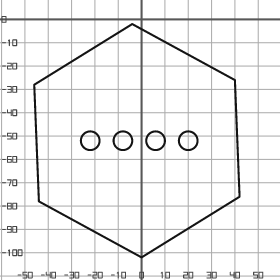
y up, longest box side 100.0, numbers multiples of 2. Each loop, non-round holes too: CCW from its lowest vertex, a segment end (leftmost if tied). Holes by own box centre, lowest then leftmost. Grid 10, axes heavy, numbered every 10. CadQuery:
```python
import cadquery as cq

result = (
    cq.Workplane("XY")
    .moveTo(0.0, -102.0)
    .lineTo(42.0, -76.0)
    .lineTo(40.0, -26.0)
    .lineTo(-4.0, -2.0)
    .lineTo(-46.0, -28.0)
    .lineTo(-44.0, -78.0)
    .close()
    .moveTo(-22.0, -52.0)
    .circle(4.0)
    .moveTo(-8.0, -52.0)
    .circle(4.0)
    .moveTo(6.0, -52.0)
    .circle(4.0)
    .moveTo(20.0, -52.0)
    .circle(4.0)
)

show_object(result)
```